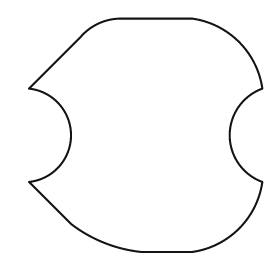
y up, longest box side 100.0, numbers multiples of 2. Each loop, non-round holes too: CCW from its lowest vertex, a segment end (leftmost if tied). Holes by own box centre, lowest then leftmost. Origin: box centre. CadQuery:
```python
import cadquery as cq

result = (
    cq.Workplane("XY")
    .moveTo(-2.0, -50.0)
    .lineTo(20.0, -50.0)
    .threePointArc((40.0, -40.0), (50.0, -20.0))
    .threePointArc((36.0, 0.0), (50.0, 20.0))
    .threePointArc((40.0, 40.0), (20.0, 50.0))
    .lineTo(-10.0, 50.0)
    .threePointArc((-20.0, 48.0), (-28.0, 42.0))
    .lineTo(-50.0, 20.0)
    .threePointArc((-32.0, 0.0), (-50.0, -20.0))
    .lineTo(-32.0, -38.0)
    .threePointArc((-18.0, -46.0), (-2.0, -50.0))
    .close()
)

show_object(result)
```